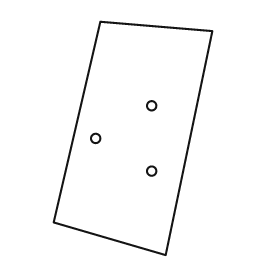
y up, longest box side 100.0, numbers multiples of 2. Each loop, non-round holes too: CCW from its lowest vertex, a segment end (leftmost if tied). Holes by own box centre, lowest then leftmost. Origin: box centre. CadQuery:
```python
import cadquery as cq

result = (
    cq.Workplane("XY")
    .moveTo(14.0, -50.0)
    .lineTo(34.0, 46.0)
    .lineTo(-14.0, 50.0)
    .lineTo(-34.0, -36.0)
    .close()
    .moveTo(8.0, -14.0)
    .circle(2.0)
    .moveTo(-16.0, 0.0)
    .circle(2.0)
    .moveTo(8.0, 14.0)
    .circle(2.0)
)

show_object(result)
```